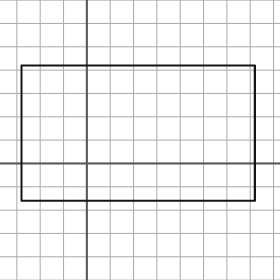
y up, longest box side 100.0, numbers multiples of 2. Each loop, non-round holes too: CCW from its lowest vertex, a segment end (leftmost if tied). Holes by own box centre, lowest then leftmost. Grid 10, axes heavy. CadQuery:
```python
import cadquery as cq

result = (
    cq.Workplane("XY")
    .moveTo(-28.0, -16.0)
    .lineTo(72.0, -16.0)
    .lineTo(72.0, 42.0)
    .lineTo(-28.0, 42.0)
    .close()
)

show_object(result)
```